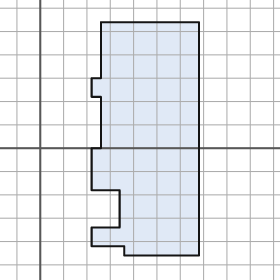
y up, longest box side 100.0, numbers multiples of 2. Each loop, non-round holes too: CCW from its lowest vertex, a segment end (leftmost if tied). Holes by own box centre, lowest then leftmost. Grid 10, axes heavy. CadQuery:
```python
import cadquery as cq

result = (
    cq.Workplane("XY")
    .moveTo(36.0, -46.0)
    .lineTo(68.0, -46.0)
    .lineTo(68.0, 54.0)
    .lineTo(26.0, 54.0)
    .lineTo(26.0, 30.0)
    .lineTo(22.0, 30.0)
    .lineTo(22.0, 22.0)
    .lineTo(26.0, 22.0)
    .lineTo(26.0, 0.0)
    .lineTo(22.0, 0.0)
    .lineTo(22.0, -18.0)
    .lineTo(34.0, -18.0)
    .lineTo(34.0, -34.0)
    .lineTo(22.0, -34.0)
    .lineTo(22.0, -42.0)
    .lineTo(36.0, -42.0)
    .close()
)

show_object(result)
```